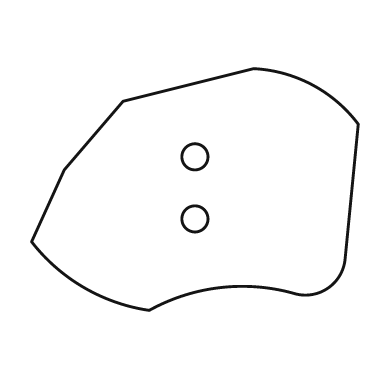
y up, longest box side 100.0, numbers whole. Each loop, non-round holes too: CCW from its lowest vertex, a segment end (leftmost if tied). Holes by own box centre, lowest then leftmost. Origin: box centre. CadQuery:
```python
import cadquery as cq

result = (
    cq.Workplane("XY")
    .moveTo(-14.0, -37.0)
    .threePointArc((8.0, -30.0), (31.0, -32.0))
    .threePointArc((41.0, -30.0), (46.0, -21.0))
    .lineTo(50.0, 20.0)
    .threePointArc((36.0, 32.0), (18.0, 37.0))
    .lineTo(-22.0, 27.0)
    .lineTo(-40.0, 6.0)
    .lineTo(-50.0, -16.0)
    .threePointArc((-34.0, -30.0), (-14.0, -37.0))
    .close()
    .moveTo(0.0, -9.0)
    .circle(4.0)
    .moveTo(0.0, 10.0)
    .circle(4.0)
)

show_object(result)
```